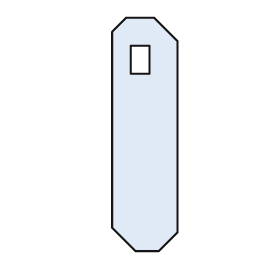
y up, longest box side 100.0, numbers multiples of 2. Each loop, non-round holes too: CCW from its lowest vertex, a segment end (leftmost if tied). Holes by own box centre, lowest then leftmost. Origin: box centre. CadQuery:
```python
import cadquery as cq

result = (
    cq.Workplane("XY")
    .moveTo(-4.0, -50.0)
    .lineTo(6.0, -50.0)
    .lineTo(14.0, -42.0)
    .lineTo(14.0, 40.0)
    .lineTo(4.0, 50.0)
    .lineTo(-8.0, 50.0)
    .lineTo(-14.0, 44.0)
    .lineTo(-14.0, -40.0)
    .close()
    .moveTo(-6.0, 26.0)
    .lineTo(2.0, 26.0)
    .lineTo(2.0, 38.0)
    .lineTo(-6.0, 38.0)
    .close()
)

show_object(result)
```